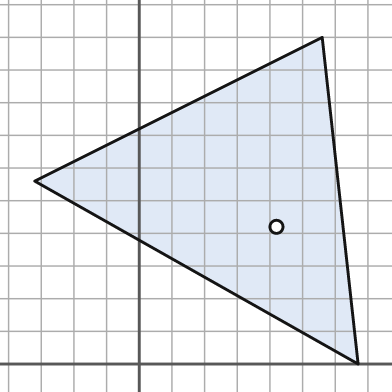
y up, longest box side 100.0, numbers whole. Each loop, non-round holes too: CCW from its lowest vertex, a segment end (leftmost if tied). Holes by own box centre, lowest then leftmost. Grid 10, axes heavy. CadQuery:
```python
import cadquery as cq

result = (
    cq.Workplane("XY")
    .moveTo(67.0, 0.0)
    .lineTo(56.0, 100.0)
    .lineTo(-32.0, 56.0)
    .close()
    .moveTo(42.0, 42.0)
    .circle(2.0)
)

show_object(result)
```